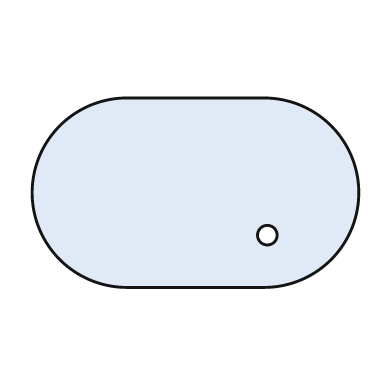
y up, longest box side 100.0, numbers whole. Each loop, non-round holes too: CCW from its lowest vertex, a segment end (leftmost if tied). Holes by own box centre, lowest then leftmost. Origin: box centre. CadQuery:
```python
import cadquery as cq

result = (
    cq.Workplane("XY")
    .moveTo(-21.0, -29.0)
    .lineTo(21.0, -29.0)
    .threePointArc((50.0, 0.0), (21.0, 29.0))
    .lineTo(-21.0, 29.0)
    .threePointArc((-50.0, 0.0), (-21.0, -29.0))
    .close()
    .moveTo(22.0, -13.0)
    .circle(3.0)
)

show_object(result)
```